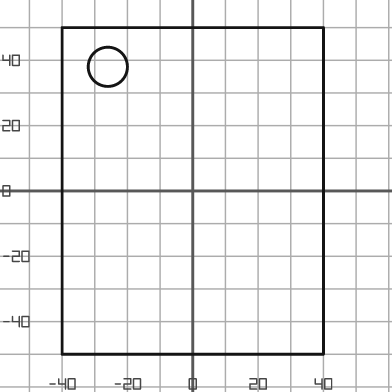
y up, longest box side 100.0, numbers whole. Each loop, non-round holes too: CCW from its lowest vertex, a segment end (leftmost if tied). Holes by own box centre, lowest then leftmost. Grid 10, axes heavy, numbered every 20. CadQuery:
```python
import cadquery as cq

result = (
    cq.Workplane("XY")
    .moveTo(-40.0, -50.0)
    .lineTo(40.0, -50.0)
    .lineTo(40.0, 50.0)
    .lineTo(-40.0, 50.0)
    .close()
    .moveTo(-26.0, 38.0)
    .circle(6.0)
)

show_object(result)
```